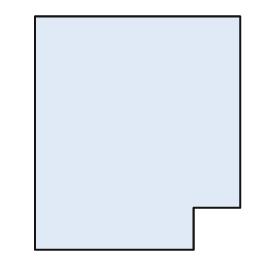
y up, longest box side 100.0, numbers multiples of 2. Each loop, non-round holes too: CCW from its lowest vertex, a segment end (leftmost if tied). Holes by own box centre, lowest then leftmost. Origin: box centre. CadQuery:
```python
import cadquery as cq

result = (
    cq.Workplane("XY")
    .moveTo(-44.0, -50.0)
    .lineTo(24.0, -50.0)
    .lineTo(24.0, -32.0)
    .lineTo(44.0, -32.0)
    .lineTo(44.0, 50.0)
    .lineTo(-44.0, 50.0)
    .close()
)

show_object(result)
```